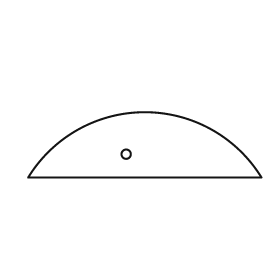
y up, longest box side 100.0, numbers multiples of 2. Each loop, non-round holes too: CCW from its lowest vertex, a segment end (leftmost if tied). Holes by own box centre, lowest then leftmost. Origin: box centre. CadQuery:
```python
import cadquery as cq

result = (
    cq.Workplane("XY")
    .moveTo(-50.0, -14.0)
    .lineTo(50.0, -14.0)
    .threePointArc((0.0, 14.0), (-50.0, -14.0))
    .close()
    .moveTo(-8.0, -4.0)
    .circle(2.0)
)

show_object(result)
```